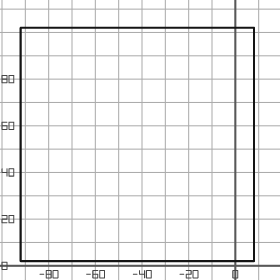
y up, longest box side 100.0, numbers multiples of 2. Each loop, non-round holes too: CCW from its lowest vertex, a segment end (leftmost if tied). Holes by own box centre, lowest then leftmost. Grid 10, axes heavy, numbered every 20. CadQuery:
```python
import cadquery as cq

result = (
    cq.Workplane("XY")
    .moveTo(-92.0, 2.0)
    .lineTo(8.0, 2.0)
    .lineTo(8.0, 102.0)
    .lineTo(-92.0, 102.0)
    .close()
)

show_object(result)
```